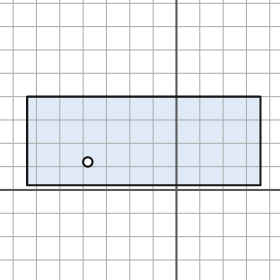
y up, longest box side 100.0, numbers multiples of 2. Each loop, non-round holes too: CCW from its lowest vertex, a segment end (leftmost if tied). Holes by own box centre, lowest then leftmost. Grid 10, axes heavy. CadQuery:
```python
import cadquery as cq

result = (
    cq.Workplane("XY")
    .moveTo(-64.0, 2.0)
    .lineTo(36.0, 2.0)
    .lineTo(36.0, 40.0)
    .lineTo(-64.0, 40.0)
    .close()
    .moveTo(-38.0, 12.0)
    .circle(2.0)
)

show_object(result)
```